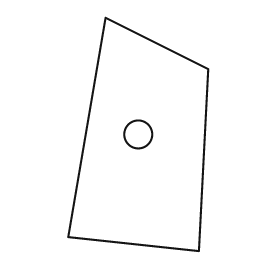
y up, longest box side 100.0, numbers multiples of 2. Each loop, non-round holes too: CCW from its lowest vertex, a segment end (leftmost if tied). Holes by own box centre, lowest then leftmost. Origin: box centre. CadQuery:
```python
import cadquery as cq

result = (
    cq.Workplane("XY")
    .moveTo(26.0, -50.0)
    .lineTo(30.0, 28.0)
    .lineTo(-14.0, 50.0)
    .lineTo(-30.0, -44.0)
    .close()
    .moveTo(0.0, 0.0)
    .circle(6.0)
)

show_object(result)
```